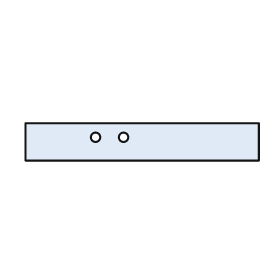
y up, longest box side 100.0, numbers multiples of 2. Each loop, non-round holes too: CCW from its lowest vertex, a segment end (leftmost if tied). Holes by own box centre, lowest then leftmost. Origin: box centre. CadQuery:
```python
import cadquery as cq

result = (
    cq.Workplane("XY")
    .moveTo(-50.0, -8.0)
    .lineTo(50.0, -8.0)
    .lineTo(50.0, 8.0)
    .lineTo(-50.0, 8.0)
    .close()
    .moveTo(-20.0, 2.0)
    .circle(2.0)
    .moveTo(-8.0, 2.0)
    .circle(2.0)
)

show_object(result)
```